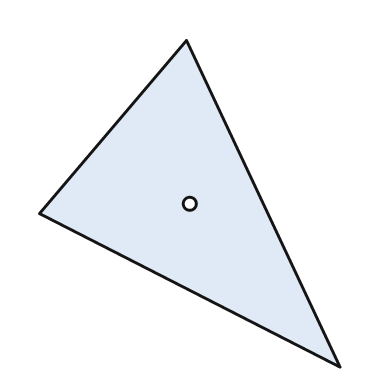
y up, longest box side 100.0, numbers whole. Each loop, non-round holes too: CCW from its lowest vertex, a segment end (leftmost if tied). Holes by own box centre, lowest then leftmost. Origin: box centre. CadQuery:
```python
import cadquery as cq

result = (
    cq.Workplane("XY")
    .moveTo(46.0, -50.0)
    .lineTo(-1.0, 50.0)
    .lineTo(-46.0, -3.0)
    .close()
    .moveTo(0.0, 0.0)
    .circle(2.0)
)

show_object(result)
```